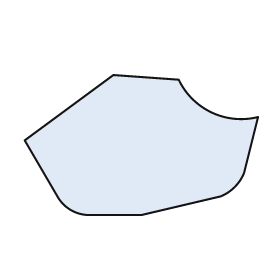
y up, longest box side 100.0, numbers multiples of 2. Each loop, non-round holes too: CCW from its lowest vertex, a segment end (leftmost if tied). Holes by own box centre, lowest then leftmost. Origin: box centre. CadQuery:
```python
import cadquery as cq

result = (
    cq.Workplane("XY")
    .moveTo(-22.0, -30.0)
    .lineTo(0.0, -30.0)
    .lineTo(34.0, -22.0)
    .threePointArc((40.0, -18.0), (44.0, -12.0))
    .lineTo(50.0, 12.0)
    .threePointArc((30.0, 14.0), (16.0, 28.0))
    .lineTo(-12.0, 30.0)
    .lineTo(-50.0, 2.0)
    .lineTo(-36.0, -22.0)
    .threePointArc((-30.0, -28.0), (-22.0, -30.0))
    .close()
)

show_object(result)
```